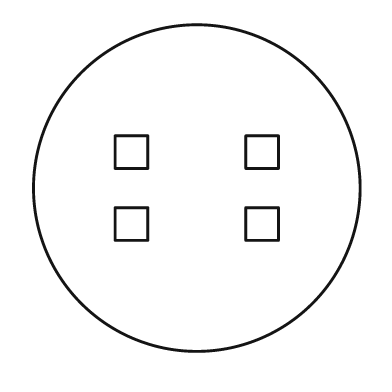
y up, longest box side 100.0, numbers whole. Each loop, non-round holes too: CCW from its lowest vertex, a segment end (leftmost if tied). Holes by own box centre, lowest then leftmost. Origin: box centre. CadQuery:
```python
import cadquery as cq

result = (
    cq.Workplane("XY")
    .moveTo(0.0, 0.0)
    .circle(50.0)
    .moveTo(-25.0, -16.0)
    .lineTo(-15.0, -16.0)
    .lineTo(-15.0, -6.0)
    .lineTo(-25.0, -6.0)
    .close()
    .moveTo(15.0, -16.0)
    .lineTo(25.0, -16.0)
    .lineTo(25.0, -6.0)
    .lineTo(15.0, -6.0)
    .close()
    .moveTo(-25.0, 6.0)
    .lineTo(-15.0, 6.0)
    .lineTo(-15.0, 16.0)
    .lineTo(-25.0, 16.0)
    .close()
    .moveTo(15.0, 6.0)
    .lineTo(25.0, 6.0)
    .lineTo(25.0, 16.0)
    .lineTo(15.0, 16.0)
    .close()
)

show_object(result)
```